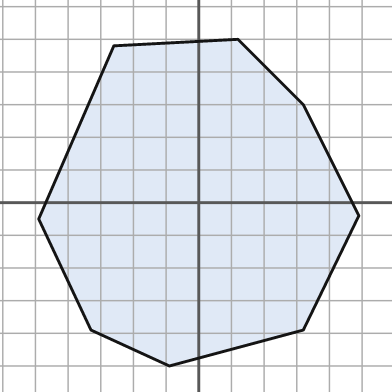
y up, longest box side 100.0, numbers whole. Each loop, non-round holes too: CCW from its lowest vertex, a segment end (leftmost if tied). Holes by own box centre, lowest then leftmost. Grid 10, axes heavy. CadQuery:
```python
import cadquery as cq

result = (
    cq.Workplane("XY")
    .moveTo(-9.0, -50.0)
    .lineTo(32.0, -39.0)
    .lineTo(49.0, -4.0)
    .lineTo(32.0, 30.0)
    .lineTo(12.0, 50.0)
    .lineTo(-26.0, 48.0)
    .lineTo(-49.0, -5.0)
    .lineTo(-33.0, -39.0)
    .close()
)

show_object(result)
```